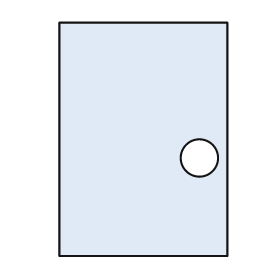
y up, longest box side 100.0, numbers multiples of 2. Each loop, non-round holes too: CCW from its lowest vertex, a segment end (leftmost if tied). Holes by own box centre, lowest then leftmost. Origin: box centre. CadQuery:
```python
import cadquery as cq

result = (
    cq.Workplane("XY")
    .moveTo(-36.0, -50.0)
    .lineTo(36.0, -50.0)
    .lineTo(36.0, 50.0)
    .lineTo(-36.0, 50.0)
    .close()
    .moveTo(24.0, -8.0)
    .circle(8.0)
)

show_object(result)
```